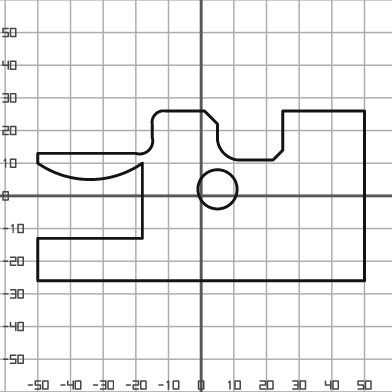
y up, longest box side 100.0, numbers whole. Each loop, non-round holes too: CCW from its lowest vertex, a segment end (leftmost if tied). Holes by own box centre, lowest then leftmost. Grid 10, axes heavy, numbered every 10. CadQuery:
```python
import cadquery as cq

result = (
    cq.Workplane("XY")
    .moveTo(-50.0, -26.0)
    .lineTo(50.0, -26.0)
    .lineTo(50.0, 26.0)
    .lineTo(25.0, 26.0)
    .lineTo(25.0, 14.0)
    .lineTo(22.0, 11.0)
    .lineTo(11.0, 11.0)
    .threePointArc((7.0, 13.0), (5.0, 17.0))
    .lineTo(5.0, 22.0)
    .lineTo(1.0, 26.0)
    .lineTo(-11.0, 26.0)
    .threePointArc((-14.0, 25.0), (-15.0, 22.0))
    .lineTo(-15.0, 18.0)
    .threePointArc((-16.0, 14.0), (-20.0, 13.0))
    .lineTo(-50.0, 13.0)
    .lineTo(-50.0, 10.0)
    .threePointArc((-34.0, 5.0), (-18.0, 10.0))
    .lineTo(-18.0, -13.0)
    .lineTo(-50.0, -13.0)
    .close()
    .moveTo(5.0, 2.0)
    .circle(6.0)
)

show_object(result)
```